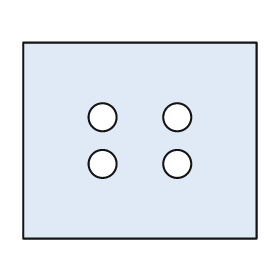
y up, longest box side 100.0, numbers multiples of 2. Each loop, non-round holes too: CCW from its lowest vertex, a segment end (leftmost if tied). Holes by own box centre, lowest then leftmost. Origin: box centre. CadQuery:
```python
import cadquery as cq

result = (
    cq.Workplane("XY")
    .moveTo(-50.0, -42.0)
    .lineTo(50.0, -42.0)
    .lineTo(50.0, 42.0)
    .lineTo(-50.0, 42.0)
    .close()
    .moveTo(-16.0, -10.0)
    .circle(6.0)
    .moveTo(16.0, -10.0)
    .circle(6.0)
    .moveTo(-16.0, 10.0)
    .circle(6.0)
    .moveTo(16.0, 10.0)
    .circle(6.0)
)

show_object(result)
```